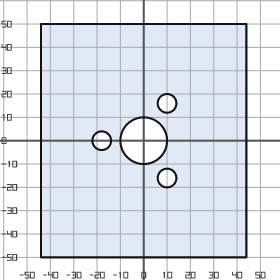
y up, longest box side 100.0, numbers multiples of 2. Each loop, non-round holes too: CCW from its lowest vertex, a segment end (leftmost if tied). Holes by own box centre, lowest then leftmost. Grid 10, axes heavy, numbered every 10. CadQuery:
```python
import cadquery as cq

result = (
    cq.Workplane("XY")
    .moveTo(-44.0, -50.0)
    .lineTo(44.0, -50.0)
    .lineTo(44.0, 50.0)
    .lineTo(-44.0, 50.0)
    .close()
    .moveTo(10.0, -16.0)
    .circle(4.0)
    .moveTo(-18.0, 0.0)
    .circle(4.0)
    .moveTo(0.0, 0.0)
    .circle(10.0)
    .moveTo(10.0, 16.0)
    .circle(4.0)
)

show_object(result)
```